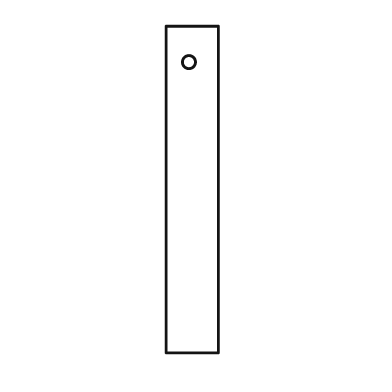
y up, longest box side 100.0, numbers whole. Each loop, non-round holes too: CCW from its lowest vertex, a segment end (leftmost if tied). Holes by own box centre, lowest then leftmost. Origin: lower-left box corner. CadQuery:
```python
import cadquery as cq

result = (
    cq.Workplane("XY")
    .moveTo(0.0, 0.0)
    .lineTo(16.0, 0.0)
    .lineTo(16.0, 100.0)
    .lineTo(0.0, 100.0)
    .close()
    .moveTo(7.0, 89.0)
    .circle(2.0)
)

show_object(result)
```